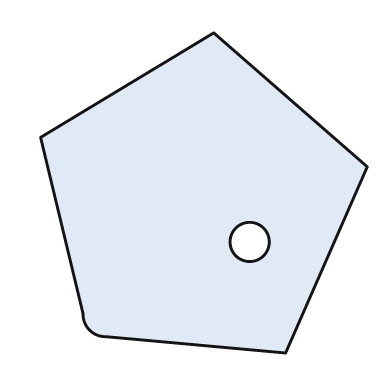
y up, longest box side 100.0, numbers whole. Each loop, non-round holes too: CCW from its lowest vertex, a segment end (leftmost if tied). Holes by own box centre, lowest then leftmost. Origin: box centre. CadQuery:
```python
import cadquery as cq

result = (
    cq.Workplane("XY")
    .moveTo(25.0, -49.0)
    .lineTo(50.0, 8.0)
    .lineTo(3.0, 49.0)
    .lineTo(-50.0, 17.0)
    .lineTo(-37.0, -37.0)
    .threePointArc((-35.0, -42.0), (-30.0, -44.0))
    .close()
    .moveTo(14.0, -15.0)
    .circle(6.0)
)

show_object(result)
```